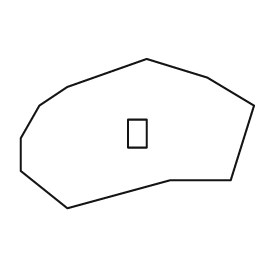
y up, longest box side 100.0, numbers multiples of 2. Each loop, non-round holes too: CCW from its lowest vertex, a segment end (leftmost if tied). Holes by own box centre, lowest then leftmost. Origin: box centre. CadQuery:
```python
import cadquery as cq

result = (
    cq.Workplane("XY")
    .moveTo(-30.0, -32.0)
    .lineTo(14.0, -20.0)
    .lineTo(40.0, -20.0)
    .lineTo(50.0, 12.0)
    .lineTo(30.0, 24.0)
    .lineTo(4.0, 32.0)
    .lineTo(-30.0, 20.0)
    .lineTo(-42.0, 12.0)
    .lineTo(-50.0, -2.0)
    .lineTo(-50.0, -16.0)
    .close()
    .moveTo(-4.0, -6.0)
    .lineTo(4.0, -6.0)
    .lineTo(4.0, 6.0)
    .lineTo(-4.0, 6.0)
    .close()
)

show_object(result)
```